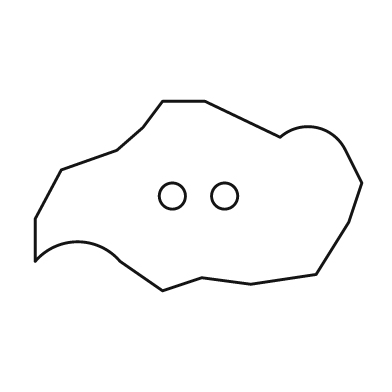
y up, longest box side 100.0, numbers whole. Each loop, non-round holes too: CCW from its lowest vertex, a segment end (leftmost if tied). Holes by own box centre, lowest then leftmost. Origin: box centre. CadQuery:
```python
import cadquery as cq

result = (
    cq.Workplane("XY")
    .moveTo(-11.0, -29.0)
    .lineTo(1.0, -25.0)
    .lineTo(16.0, -27.0)
    .lineTo(36.0, -24.0)
    .lineTo(46.0, -8.0)
    .lineTo(50.0, 4.0)
    .lineTo(45.0, 14.0)
    .threePointArc((36.0, 21.0), (25.0, 18.0))
    .lineTo(2.0, 29.0)
    .lineTo(-11.0, 29.0)
    .lineTo(-17.0, 21.0)
    .lineTo(-25.0, 14.0)
    .lineTo(-42.0, 8.0)
    .lineTo(-50.0, -7.0)
    .lineTo(-50.0, -20.0)
    .threePointArc((-37.0, -14.0), (-24.0, -20.0))
    .close()
    .moveTo(-8.0, 0.0)
    .circle(4.0)
    .moveTo(8.0, 0.0)
    .circle(4.0)
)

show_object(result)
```